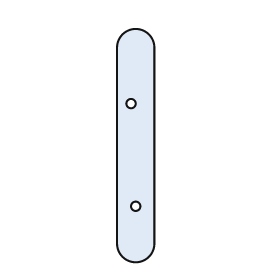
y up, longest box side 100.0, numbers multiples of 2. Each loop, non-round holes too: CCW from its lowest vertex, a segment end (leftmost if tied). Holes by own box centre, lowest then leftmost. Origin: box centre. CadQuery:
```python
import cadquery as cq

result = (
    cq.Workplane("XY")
    .moveTo(-8.0, -42.0)
    .threePointArc((0.0, -50.0), (8.0, -42.0))
    .lineTo(8.0, 42.0)
    .threePointArc((0.0, 50.0), (-8.0, 42.0))
    .close()
    .moveTo(0.0, -26.0)
    .circle(2.0)
    .moveTo(-2.0, 18.0)
    .circle(2.0)
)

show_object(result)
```